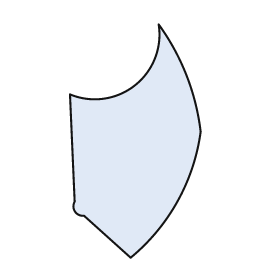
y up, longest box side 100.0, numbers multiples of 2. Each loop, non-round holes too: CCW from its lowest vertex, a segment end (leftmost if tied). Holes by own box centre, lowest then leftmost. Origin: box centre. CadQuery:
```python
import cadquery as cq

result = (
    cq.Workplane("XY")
    .moveTo(-2.0, -50.0)
    .threePointArc((18.0, -26.0), (28.0, 4.0))
    .threePointArc((22.0, 28.0), (10.0, 50.0))
    .threePointArc((0.0, 24.0), (-28.0, 20.0))
    .lineTo(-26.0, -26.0)
    .threePointArc((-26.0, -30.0), (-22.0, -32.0))
    .close()
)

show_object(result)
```